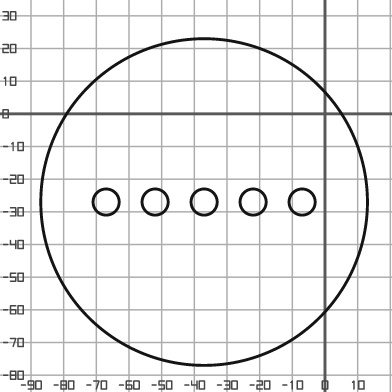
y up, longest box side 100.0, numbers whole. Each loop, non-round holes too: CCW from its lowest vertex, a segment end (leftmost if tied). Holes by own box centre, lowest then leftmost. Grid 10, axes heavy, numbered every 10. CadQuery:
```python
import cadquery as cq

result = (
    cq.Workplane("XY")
    .moveTo(-37.0, -27.0)
    .circle(50.0)
    .moveTo(-67.0, -27.0)
    .circle(4.0)
    .moveTo(-52.0, -27.0)
    .circle(4.0)
    .moveTo(-37.0, -27.0)
    .circle(4.0)
    .moveTo(-22.0, -27.0)
    .circle(4.0)
    .moveTo(-7.0, -27.0)
    .circle(4.0)
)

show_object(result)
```